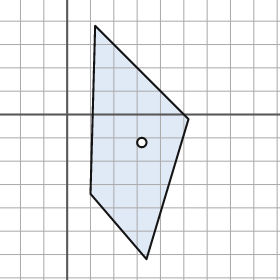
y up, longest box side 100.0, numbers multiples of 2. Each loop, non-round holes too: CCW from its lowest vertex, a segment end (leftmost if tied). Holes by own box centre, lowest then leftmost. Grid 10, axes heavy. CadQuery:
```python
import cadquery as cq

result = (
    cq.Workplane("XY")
    .moveTo(34.0, -62.0)
    .lineTo(52.0, -2.0)
    .lineTo(12.0, 38.0)
    .lineTo(10.0, -34.0)
    .close()
    .moveTo(32.0, -12.0)
    .circle(2.0)
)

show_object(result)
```